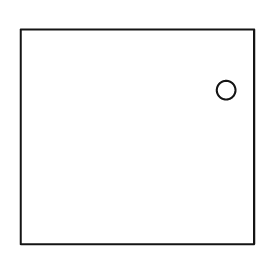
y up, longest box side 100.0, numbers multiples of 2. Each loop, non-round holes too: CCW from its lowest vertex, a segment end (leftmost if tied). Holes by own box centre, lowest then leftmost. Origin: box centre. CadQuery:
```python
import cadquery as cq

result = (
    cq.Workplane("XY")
    .moveTo(-50.0, -46.0)
    .lineTo(50.0, -46.0)
    .lineTo(50.0, 46.0)
    .lineTo(-50.0, 46.0)
    .close()
    .moveTo(38.0, 20.0)
    .circle(4.0)
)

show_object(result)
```